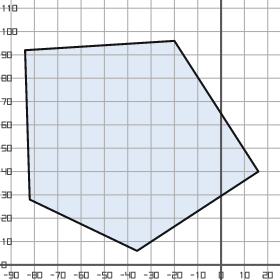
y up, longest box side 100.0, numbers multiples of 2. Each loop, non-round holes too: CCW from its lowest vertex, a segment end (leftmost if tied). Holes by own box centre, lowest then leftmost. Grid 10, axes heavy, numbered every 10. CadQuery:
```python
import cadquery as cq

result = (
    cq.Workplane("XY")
    .moveTo(-36.0, 6.0)
    .lineTo(16.0, 40.0)
    .lineTo(-20.0, 96.0)
    .lineTo(-84.0, 92.0)
    .lineTo(-82.0, 28.0)
    .close()
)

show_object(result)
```